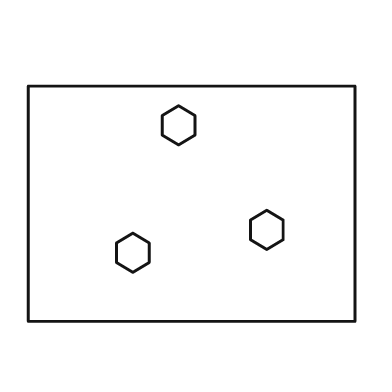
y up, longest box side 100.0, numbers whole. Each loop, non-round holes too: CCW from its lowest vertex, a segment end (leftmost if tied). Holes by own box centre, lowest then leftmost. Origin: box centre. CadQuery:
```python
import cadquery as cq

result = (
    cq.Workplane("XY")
    .moveTo(-50.0, -36.0)
    .lineTo(50.0, -36.0)
    .lineTo(50.0, 36.0)
    .lineTo(-50.0, 36.0)
    .close()
    .moveTo(-18.0, -21.0)
    .lineTo(-13.0, -18.0)
    .lineTo(-13.0, -12.0)
    .lineTo(-18.0, -9.0)
    .lineTo(-23.0, -12.0)
    .lineTo(-23.0, -18.0)
    .close()
    .moveTo(23.0, -14.0)
    .lineTo(28.0, -11.0)
    .lineTo(28.0, -5.0)
    .lineTo(23.0, -2.0)
    .lineTo(18.0, -5.0)
    .lineTo(18.0, -11.0)
    .close()
    .moveTo(-4.0, 18.0)
    .lineTo(1.0, 21.0)
    .lineTo(1.0, 27.0)
    .lineTo(-4.0, 30.0)
    .lineTo(-9.0, 27.0)
    .lineTo(-9.0, 21.0)
    .close()
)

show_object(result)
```